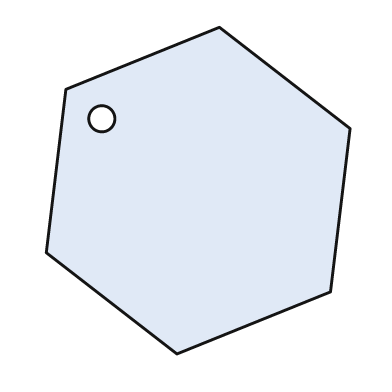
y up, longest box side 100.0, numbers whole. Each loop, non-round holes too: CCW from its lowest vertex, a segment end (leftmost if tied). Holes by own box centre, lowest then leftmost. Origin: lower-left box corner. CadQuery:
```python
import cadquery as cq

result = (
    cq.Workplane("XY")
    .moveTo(40.0, 0.0)
    .lineTo(87.0, 19.0)
    .lineTo(93.0, 69.0)
    .lineTo(53.0, 100.0)
    .lineTo(6.0, 81.0)
    .lineTo(0.0, 31.0)
    .close()
    .moveTo(17.0, 72.0)
    .circle(4.0)
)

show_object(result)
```